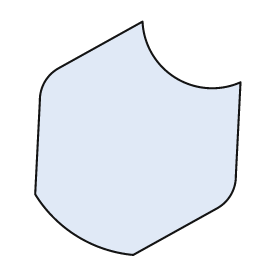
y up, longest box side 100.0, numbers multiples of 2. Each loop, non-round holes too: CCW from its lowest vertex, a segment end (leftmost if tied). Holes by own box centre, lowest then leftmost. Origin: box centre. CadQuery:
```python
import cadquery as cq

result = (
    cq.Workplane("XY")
    .moveTo(-2.0, -50.0)
    .lineTo(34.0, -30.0)
    .threePointArc((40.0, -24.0), (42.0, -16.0))
    .lineTo(44.0, 24.0)
    .threePointArc((16.0, 26.0), (2.0, 50.0))
    .lineTo(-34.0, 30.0)
    .threePointArc((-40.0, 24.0), (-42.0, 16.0))
    .lineTo(-44.0, -24.0)
    .threePointArc((-26.0, -42.0), (-2.0, -50.0))
    .close()
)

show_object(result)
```